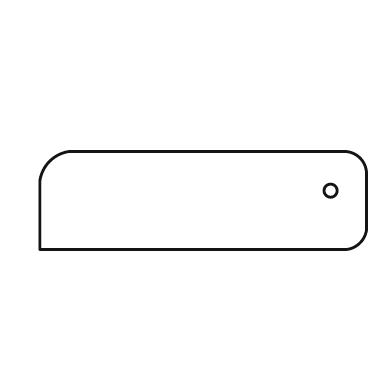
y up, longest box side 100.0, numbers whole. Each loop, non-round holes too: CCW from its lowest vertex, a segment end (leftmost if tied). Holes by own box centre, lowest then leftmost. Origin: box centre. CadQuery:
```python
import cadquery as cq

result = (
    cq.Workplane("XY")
    .moveTo(-50.0, -15.0)
    .lineTo(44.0, -15.0)
    .threePointArc((48.0, -13.0), (50.0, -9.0))
    .lineTo(50.0, 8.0)
    .threePointArc((48.0, 13.0), (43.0, 15.0))
    .lineTo(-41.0, 15.0)
    .threePointArc((-47.0, 12.0), (-50.0, 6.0))
    .close()
    .moveTo(39.0, 3.0)
    .circle(2.0)
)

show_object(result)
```